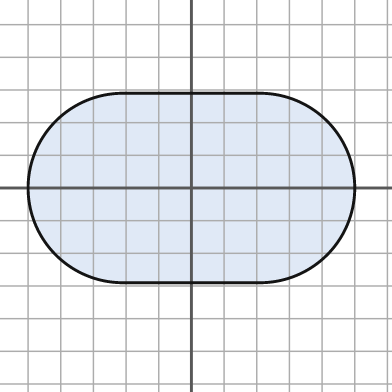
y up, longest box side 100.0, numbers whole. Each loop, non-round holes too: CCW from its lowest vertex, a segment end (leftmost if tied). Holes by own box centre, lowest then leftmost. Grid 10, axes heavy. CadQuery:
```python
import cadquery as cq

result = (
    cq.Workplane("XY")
    .moveTo(-21.0, -29.0)
    .lineTo(21.0, -29.0)
    .threePointArc((50.0, 0.0), (21.0, 29.0))
    .lineTo(-21.0, 29.0)
    .threePointArc((-50.0, 0.0), (-21.0, -29.0))
    .close()
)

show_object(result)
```